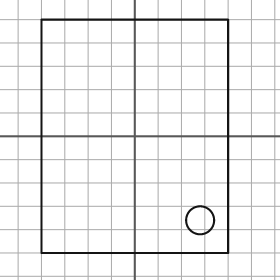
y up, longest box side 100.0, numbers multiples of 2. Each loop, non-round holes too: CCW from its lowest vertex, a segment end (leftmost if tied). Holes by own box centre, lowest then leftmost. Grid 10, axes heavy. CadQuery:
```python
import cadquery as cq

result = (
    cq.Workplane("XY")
    .moveTo(-40.0, -50.0)
    .lineTo(40.0, -50.0)
    .lineTo(40.0, 50.0)
    .lineTo(-40.0, 50.0)
    .close()
    .moveTo(28.0, -36.0)
    .circle(6.0)
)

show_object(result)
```